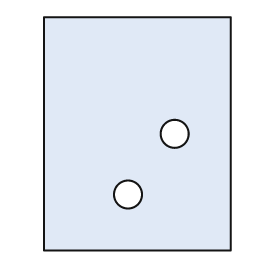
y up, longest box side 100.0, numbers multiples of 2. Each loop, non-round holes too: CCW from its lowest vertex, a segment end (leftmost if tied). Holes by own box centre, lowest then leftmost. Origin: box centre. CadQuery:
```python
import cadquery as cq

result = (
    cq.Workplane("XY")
    .moveTo(-40.0, -50.0)
    .lineTo(40.0, -50.0)
    .lineTo(40.0, 50.0)
    .lineTo(-40.0, 50.0)
    .close()
    .moveTo(-4.0, -26.0)
    .circle(6.0)
    .moveTo(16.0, 0.0)
    .circle(6.0)
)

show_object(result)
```